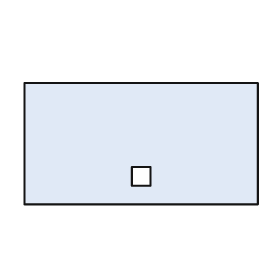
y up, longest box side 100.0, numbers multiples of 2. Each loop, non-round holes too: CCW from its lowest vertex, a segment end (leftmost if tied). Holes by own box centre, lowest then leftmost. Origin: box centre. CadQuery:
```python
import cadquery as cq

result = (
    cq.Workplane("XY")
    .moveTo(-50.0, -26.0)
    .lineTo(50.0, -26.0)
    .lineTo(50.0, 26.0)
    .lineTo(-50.0, 26.0)
    .close()
    .moveTo(-4.0, -18.0)
    .lineTo(4.0, -18.0)
    .lineTo(4.0, -10.0)
    .lineTo(-4.0, -10.0)
    .close()
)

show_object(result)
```